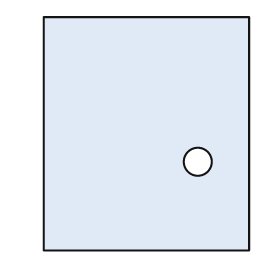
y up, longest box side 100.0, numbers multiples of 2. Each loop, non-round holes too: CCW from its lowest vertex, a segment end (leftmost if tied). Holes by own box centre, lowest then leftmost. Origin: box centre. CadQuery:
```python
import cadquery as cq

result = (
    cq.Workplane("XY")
    .moveTo(-44.0, -50.0)
    .lineTo(44.0, -50.0)
    .lineTo(44.0, 50.0)
    .lineTo(-44.0, 50.0)
    .close()
    .moveTo(22.0, -12.0)
    .circle(6.0)
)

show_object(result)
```